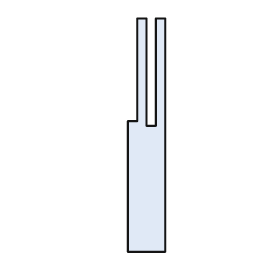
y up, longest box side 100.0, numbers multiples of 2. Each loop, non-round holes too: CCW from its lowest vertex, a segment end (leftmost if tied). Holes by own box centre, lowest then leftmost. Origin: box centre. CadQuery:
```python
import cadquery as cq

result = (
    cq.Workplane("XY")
    .moveTo(-8.0, -50.0)
    .lineTo(8.0, -50.0)
    .lineTo(8.0, 50.0)
    .lineTo(4.0, 50.0)
    .lineTo(4.0, 4.0)
    .lineTo(0.0, 4.0)
    .lineTo(0.0, 50.0)
    .lineTo(-4.0, 50.0)
    .lineTo(-4.0, 6.0)
    .lineTo(-8.0, 6.0)
    .close()
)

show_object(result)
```